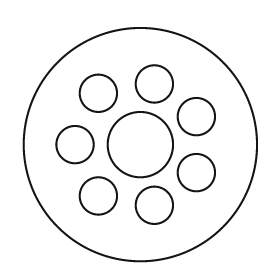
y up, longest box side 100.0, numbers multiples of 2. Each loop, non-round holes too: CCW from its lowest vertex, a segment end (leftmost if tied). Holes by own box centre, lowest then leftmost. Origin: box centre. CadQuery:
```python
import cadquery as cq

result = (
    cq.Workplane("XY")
    .moveTo(0.0, 0.0)
    .circle(50.0)
    .moveTo(6.0, -26.0)
    .circle(8.0)
    .moveTo(-18.0, -22.0)
    .circle(8.0)
    .moveTo(24.0, -12.0)
    .circle(8.0)
    .moveTo(-28.0, 0.0)
    .circle(8.0)
    .moveTo(0.0, 0.0)
    .circle(14.0)
    .moveTo(24.0, 12.0)
    .circle(8.0)
    .moveTo(-18.0, 22.0)
    .circle(8.0)
    .moveTo(6.0, 26.0)
    .circle(8.0)
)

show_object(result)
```